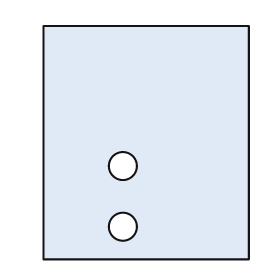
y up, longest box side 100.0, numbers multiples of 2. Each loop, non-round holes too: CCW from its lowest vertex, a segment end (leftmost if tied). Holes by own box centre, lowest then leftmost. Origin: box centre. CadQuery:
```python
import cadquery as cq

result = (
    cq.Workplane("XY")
    .moveTo(-44.0, -50.0)
    .lineTo(44.0, -50.0)
    .lineTo(44.0, 50.0)
    .lineTo(-44.0, 50.0)
    .close()
    .moveTo(-10.0, -36.0)
    .circle(6.0)
    .moveTo(-10.0, -10.0)
    .circle(6.0)
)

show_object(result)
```